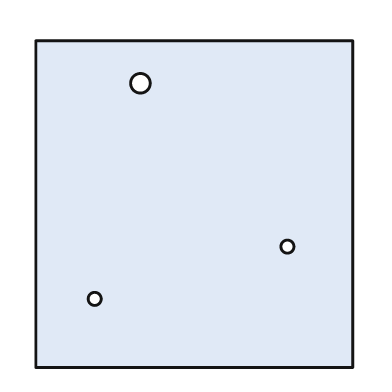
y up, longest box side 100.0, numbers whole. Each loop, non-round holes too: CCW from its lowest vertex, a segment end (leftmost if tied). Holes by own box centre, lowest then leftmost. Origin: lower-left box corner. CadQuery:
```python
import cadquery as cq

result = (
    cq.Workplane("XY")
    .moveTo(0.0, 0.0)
    .lineTo(97.0, 0.0)
    .lineTo(97.0, 100.0)
    .lineTo(0.0, 100.0)
    .close()
    .moveTo(18.0, 21.0)
    .circle(2.0)
    .moveTo(77.0, 37.0)
    .circle(2.0)
    .moveTo(32.0, 87.0)
    .circle(3.0)
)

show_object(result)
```